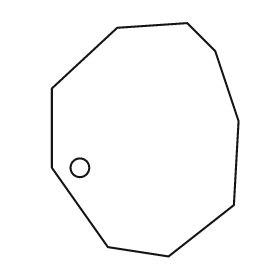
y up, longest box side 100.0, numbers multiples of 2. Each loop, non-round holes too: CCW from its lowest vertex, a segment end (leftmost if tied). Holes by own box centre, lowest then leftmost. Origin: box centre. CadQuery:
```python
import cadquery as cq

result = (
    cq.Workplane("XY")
    .moveTo(10.0, -50.0)
    .lineTo(38.0, -28.0)
    .lineTo(40.0, 8.0)
    .lineTo(30.0, 38.0)
    .lineTo(18.0, 50.0)
    .lineTo(-12.0, 48.0)
    .lineTo(-40.0, 22.0)
    .lineTo(-40.0, -12.0)
    .lineTo(-16.0, -46.0)
    .close()
    .moveTo(-28.0, -12.0)
    .circle(4.0)
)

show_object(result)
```